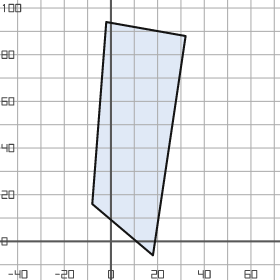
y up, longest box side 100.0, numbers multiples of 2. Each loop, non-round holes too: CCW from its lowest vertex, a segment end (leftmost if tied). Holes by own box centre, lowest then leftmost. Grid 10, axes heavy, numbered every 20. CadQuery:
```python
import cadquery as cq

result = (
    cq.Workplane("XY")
    .moveTo(18.0, -6.0)
    .lineTo(32.0, 88.0)
    .lineTo(-2.0, 94.0)
    .lineTo(-8.0, 16.0)
    .close()
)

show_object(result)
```